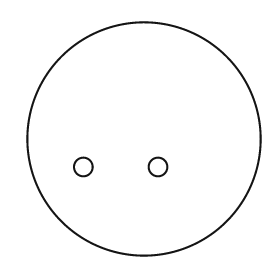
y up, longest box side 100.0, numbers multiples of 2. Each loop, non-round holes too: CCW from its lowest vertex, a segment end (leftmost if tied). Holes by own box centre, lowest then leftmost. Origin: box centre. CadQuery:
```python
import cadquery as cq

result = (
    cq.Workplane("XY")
    .moveTo(0.0, 0.0)
    .circle(50.0)
    .moveTo(-26.0, -12.0)
    .circle(4.0)
    .moveTo(6.0, -12.0)
    .circle(4.0)
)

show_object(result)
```